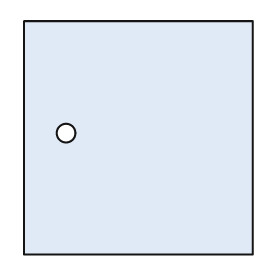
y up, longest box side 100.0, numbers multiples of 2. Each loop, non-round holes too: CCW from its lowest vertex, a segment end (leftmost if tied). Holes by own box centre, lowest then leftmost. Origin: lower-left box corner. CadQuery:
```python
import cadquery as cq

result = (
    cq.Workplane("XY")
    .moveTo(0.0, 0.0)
    .lineTo(98.0, 0.0)
    .lineTo(98.0, 100.0)
    .lineTo(0.0, 100.0)
    .close()
    .moveTo(18.0, 52.0)
    .circle(4.0)
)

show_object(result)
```